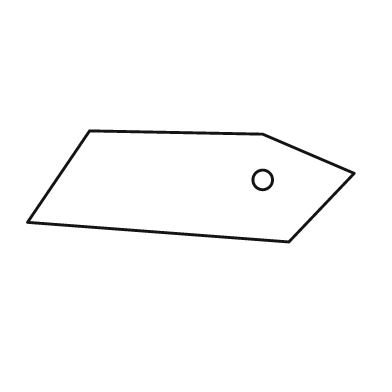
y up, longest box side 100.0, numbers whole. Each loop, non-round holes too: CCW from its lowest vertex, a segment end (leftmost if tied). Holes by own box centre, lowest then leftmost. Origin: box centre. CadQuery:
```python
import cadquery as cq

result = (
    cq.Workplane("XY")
    .moveTo(30.0, -17.0)
    .lineTo(50.0, 4.0)
    .lineTo(22.0, 16.0)
    .lineTo(-31.0, 17.0)
    .lineTo(-50.0, -11.0)
    .close()
    .moveTo(22.0, 2.0)
    .circle(3.0)
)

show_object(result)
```